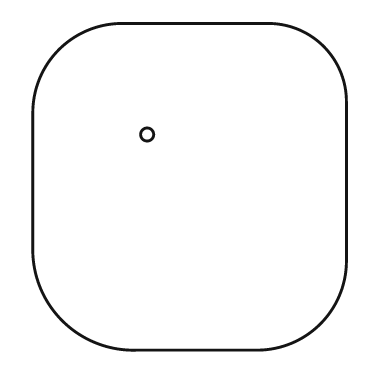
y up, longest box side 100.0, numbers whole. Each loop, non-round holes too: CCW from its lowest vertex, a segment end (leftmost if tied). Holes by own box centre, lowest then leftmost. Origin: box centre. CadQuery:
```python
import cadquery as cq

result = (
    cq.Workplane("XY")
    .moveTo(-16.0, -50.0)
    .lineTo(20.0, -50.0)
    .threePointArc((40.0, -42.0), (48.0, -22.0))
    .lineTo(48.0, 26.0)
    .threePointArc((41.0, 43.0), (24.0, 50.0))
    .lineTo(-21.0, 50.0)
    .threePointArc((-40.0, 42.0), (-48.0, 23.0))
    .lineTo(-48.0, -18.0)
    .threePointArc((-39.0, -41.0), (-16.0, -50.0))
    .close()
    .moveTo(-13.0, 16.0)
    .circle(2.0)
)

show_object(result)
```